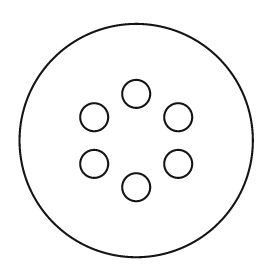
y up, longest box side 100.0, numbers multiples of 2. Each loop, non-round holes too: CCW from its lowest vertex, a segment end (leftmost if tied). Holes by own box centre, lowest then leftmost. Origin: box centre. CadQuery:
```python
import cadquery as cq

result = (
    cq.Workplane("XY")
    .moveTo(0.0, 0.0)
    .circle(50.0)
    .moveTo(0.0, -20.0)
    .circle(6.0)
    .moveTo(-18.0, -10.0)
    .circle(6.0)
    .moveTo(18.0, -10.0)
    .circle(6.0)
    .moveTo(-18.0, 10.0)
    .circle(6.0)
    .moveTo(18.0, 10.0)
    .circle(6.0)
    .moveTo(0.0, 20.0)
    .circle(6.0)
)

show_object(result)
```